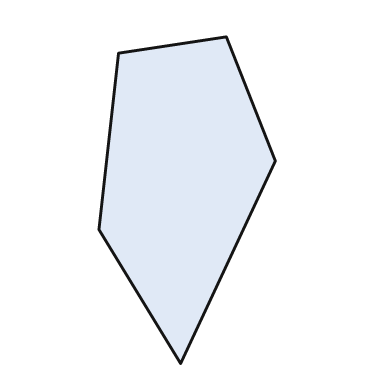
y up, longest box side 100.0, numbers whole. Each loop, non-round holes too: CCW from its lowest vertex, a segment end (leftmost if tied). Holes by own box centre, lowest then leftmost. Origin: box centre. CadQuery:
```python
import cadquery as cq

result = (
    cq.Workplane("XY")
    .moveTo(-2.0, -50.0)
    .lineTo(27.0, 12.0)
    .lineTo(12.0, 50.0)
    .lineTo(-21.0, 45.0)
    .lineTo(-27.0, -9.0)
    .close()
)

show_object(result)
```